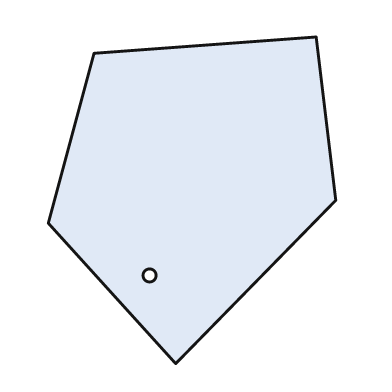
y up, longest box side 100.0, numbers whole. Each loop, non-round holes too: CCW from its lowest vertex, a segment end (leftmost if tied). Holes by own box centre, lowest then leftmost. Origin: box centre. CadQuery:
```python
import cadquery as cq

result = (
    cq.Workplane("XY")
    .moveTo(-5.0, -50.0)
    .lineTo(44.0, 0.0)
    .lineTo(38.0, 50.0)
    .lineTo(-30.0, 45.0)
    .lineTo(-44.0, -7.0)
    .close()
    .moveTo(-13.0, -23.0)
    .circle(2.0)
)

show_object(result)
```